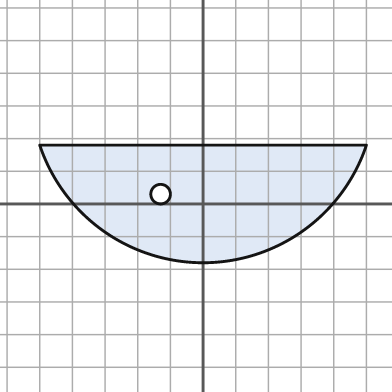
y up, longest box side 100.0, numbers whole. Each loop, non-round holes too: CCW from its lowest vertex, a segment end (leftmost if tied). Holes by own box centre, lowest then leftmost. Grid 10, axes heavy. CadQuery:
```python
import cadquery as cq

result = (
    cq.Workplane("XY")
    .moveTo(-50.0, 18.0)
    .threePointArc((0.0, -18.0), (50.0, 18.0))
    .close()
    .moveTo(-13.0, 3.0)
    .circle(3.0)
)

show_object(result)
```